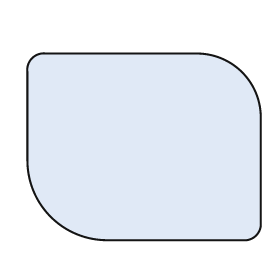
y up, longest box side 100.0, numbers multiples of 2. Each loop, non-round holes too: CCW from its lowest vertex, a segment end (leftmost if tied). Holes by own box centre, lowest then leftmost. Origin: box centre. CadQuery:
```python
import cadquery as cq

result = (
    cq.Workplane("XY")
    .moveTo(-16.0, -40.0)
    .lineTo(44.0, -40.0)
    .threePointArc((48.0, -38.0), (50.0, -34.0))
    .lineTo(50.0, 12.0)
    .threePointArc((42.0, 32.0), (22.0, 40.0))
    .lineTo(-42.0, 40.0)
    .threePointArc((-48.0, 38.0), (-50.0, 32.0))
    .lineTo(-50.0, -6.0)
    .threePointArc((-40.0, -30.0), (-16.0, -40.0))
    .close()
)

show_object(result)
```